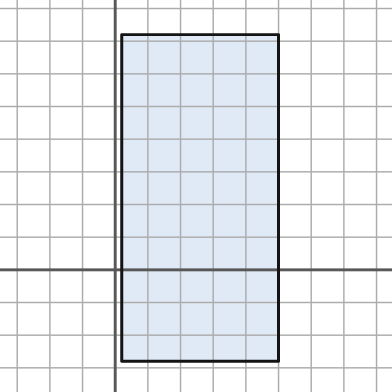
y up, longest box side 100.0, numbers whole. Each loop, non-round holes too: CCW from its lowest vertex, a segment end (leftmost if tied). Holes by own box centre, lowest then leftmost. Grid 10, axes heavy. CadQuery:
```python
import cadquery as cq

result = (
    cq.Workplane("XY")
    .moveTo(2.0, -28.0)
    .lineTo(50.0, -28.0)
    .lineTo(50.0, 72.0)
    .lineTo(2.0, 72.0)
    .close()
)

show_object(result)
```